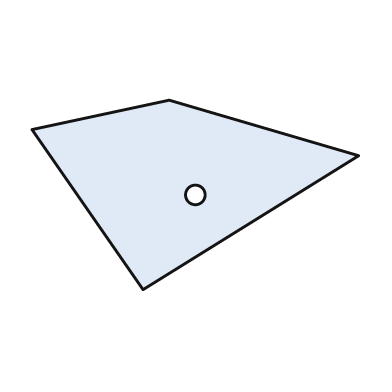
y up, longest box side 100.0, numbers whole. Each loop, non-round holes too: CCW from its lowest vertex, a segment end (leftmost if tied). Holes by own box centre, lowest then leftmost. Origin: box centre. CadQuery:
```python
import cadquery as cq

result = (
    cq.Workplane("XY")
    .moveTo(-16.0, -29.0)
    .lineTo(50.0, 12.0)
    .lineTo(-8.0, 29.0)
    .lineTo(-50.0, 20.0)
    .close()
    .moveTo(0.0, 0.0)
    .circle(3.0)
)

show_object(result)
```